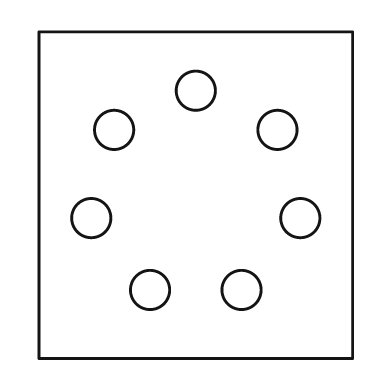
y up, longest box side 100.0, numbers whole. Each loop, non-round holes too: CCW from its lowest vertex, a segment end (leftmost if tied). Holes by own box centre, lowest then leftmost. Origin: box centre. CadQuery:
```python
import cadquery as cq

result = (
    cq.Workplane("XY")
    .moveTo(-48.0, -50.0)
    .lineTo(48.0, -50.0)
    .lineTo(48.0, 50.0)
    .lineTo(-48.0, 50.0)
    .close()
    .moveTo(-14.0, -29.0)
    .circle(6.0)
    .moveTo(14.0, -29.0)
    .circle(6.0)
    .moveTo(-32.0, -7.0)
    .circle(6.0)
    .moveTo(32.0, -7.0)
    .circle(6.0)
    .moveTo(-25.0, 20.0)
    .circle(6.0)
    .moveTo(25.0, 20.0)
    .circle(6.0)
    .moveTo(0.0, 32.0)
    .circle(6.0)
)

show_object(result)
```